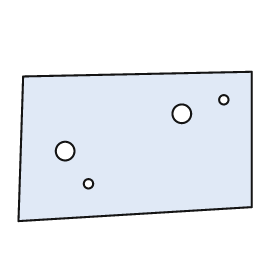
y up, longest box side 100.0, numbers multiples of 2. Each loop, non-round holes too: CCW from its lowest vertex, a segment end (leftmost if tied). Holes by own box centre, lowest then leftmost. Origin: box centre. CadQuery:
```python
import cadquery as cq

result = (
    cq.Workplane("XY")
    .moveTo(-50.0, -32.0)
    .lineTo(50.0, -26.0)
    .lineTo(50.0, 32.0)
    .lineTo(-48.0, 30.0)
    .close()
    .moveTo(-20.0, -16.0)
    .circle(2.0)
    .moveTo(-30.0, -2.0)
    .circle(4.0)
    .moveTo(20.0, 14.0)
    .circle(4.0)
    .moveTo(38.0, 20.0)
    .circle(2.0)
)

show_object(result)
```